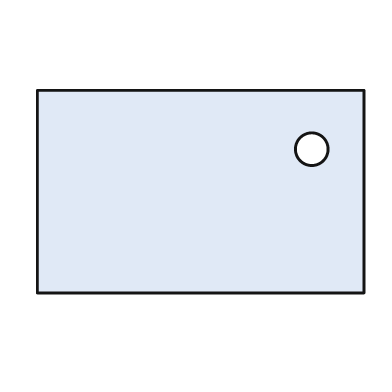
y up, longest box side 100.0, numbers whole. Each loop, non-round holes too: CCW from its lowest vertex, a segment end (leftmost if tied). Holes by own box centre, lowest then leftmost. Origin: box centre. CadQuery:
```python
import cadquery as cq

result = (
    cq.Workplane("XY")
    .moveTo(-50.0, -31.0)
    .lineTo(50.0, -31.0)
    .lineTo(50.0, 31.0)
    .lineTo(-50.0, 31.0)
    .close()
    .moveTo(34.0, 13.0)
    .circle(5.0)
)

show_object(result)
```